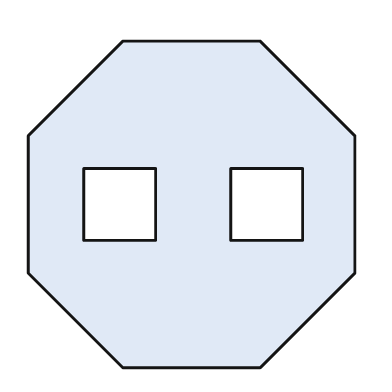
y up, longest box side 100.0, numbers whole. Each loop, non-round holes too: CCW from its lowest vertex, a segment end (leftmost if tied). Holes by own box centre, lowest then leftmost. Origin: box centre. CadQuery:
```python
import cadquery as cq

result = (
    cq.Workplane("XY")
    .moveTo(-21.0, -50.0)
    .lineTo(21.0, -50.0)
    .lineTo(50.0, -21.0)
    .lineTo(50.0, 21.0)
    .lineTo(21.0, 50.0)
    .lineTo(-21.0, 50.0)
    .lineTo(-50.0, 21.0)
    .lineTo(-50.0, -21.0)
    .close()
    .moveTo(-33.0, -11.0)
    .lineTo(-11.0, -11.0)
    .lineTo(-11.0, 11.0)
    .lineTo(-33.0, 11.0)
    .close()
    .moveTo(12.0, -11.0)
    .lineTo(34.0, -11.0)
    .lineTo(34.0, 11.0)
    .lineTo(12.0, 11.0)
    .close()
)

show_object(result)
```